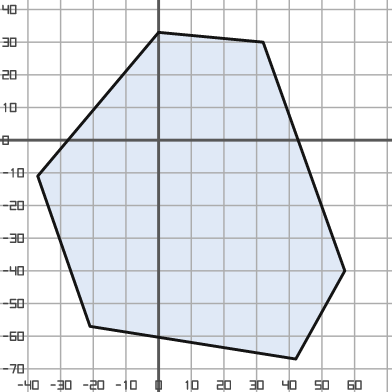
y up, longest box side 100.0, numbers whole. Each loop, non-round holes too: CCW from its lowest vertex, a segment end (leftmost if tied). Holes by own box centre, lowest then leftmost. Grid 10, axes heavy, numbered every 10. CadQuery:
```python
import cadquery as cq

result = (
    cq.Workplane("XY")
    .moveTo(42.0, -67.0)
    .lineTo(57.0, -40.0)
    .lineTo(32.0, 30.0)
    .lineTo(0.0, 33.0)
    .lineTo(-37.0, -11.0)
    .lineTo(-21.0, -57.0)
    .close()
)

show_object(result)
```